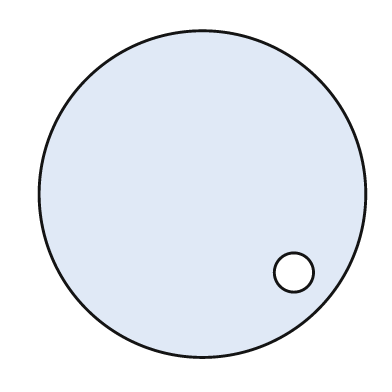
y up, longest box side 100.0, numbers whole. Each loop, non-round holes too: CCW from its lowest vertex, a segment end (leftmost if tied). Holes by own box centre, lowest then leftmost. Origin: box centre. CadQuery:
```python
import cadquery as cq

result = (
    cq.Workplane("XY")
    .moveTo(0.0, 0.0)
    .circle(50.0)
    .moveTo(28.0, -24.0)
    .circle(6.0)
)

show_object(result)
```